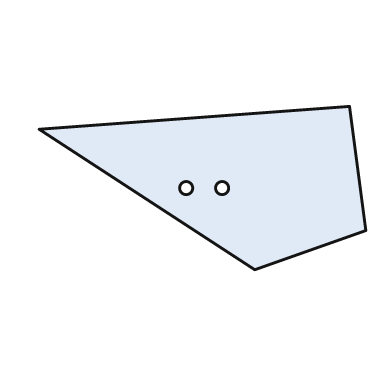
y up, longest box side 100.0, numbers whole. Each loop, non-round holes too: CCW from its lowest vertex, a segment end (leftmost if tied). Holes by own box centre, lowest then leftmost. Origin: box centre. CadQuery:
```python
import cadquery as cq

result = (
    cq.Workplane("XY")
    .moveTo(16.0, -25.0)
    .lineTo(50.0, -13.0)
    .lineTo(45.0, 25.0)
    .lineTo(-50.0, 18.0)
    .close()
    .moveTo(-5.0, 0.0)
    .circle(2.0)
    .moveTo(6.0, 0.0)
    .circle(2.0)
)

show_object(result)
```